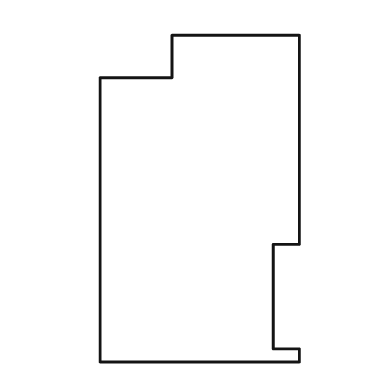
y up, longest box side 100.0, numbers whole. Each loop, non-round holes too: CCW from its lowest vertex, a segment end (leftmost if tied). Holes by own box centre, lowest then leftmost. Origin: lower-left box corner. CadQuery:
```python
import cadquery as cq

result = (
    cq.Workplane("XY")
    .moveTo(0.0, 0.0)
    .lineTo(61.0, 0.0)
    .lineTo(61.0, 4.0)
    .lineTo(53.0, 4.0)
    .lineTo(53.0, 36.0)
    .lineTo(61.0, 36.0)
    .lineTo(61.0, 100.0)
    .lineTo(22.0, 100.0)
    .lineTo(22.0, 87.0)
    .lineTo(0.0, 87.0)
    .close()
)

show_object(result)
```